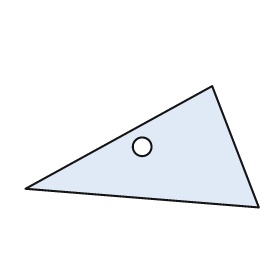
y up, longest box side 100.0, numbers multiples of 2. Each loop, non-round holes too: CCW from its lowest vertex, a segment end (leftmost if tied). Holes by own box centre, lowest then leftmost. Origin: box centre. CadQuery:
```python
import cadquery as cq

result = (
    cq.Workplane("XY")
    .moveTo(50.0, -26.0)
    .lineTo(30.0, 26.0)
    .lineTo(-50.0, -18.0)
    .close()
    .moveTo(0.0, 0.0)
    .circle(4.0)
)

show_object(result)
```